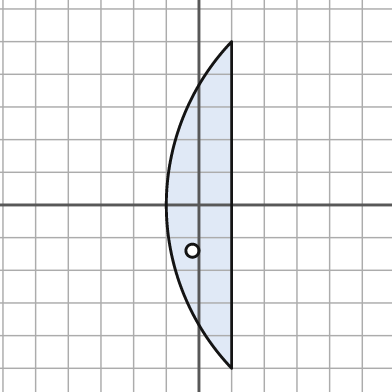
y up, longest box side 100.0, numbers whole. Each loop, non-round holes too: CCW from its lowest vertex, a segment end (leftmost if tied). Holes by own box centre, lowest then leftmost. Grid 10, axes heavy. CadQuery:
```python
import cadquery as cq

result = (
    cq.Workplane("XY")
    .moveTo(10.0, -50.0)
    .lineTo(10.0, 50.0)
    .threePointArc((-10.0, 0.0), (10.0, -50.0))
    .close()
    .moveTo(-2.0, -14.0)
    .circle(2.0)
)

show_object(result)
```